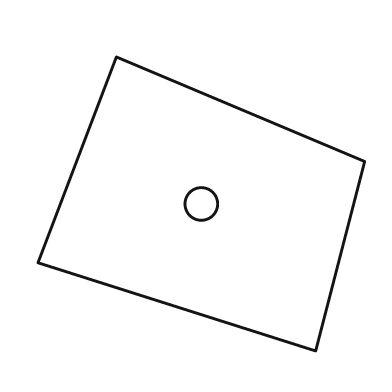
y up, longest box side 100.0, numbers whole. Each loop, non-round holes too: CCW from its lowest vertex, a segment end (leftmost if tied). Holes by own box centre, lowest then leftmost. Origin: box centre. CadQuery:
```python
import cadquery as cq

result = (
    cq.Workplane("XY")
    .moveTo(35.0, -45.0)
    .lineTo(50.0, 13.0)
    .lineTo(-26.0, 45.0)
    .lineTo(-50.0, -18.0)
    .close()
    .moveTo(0.0, 0.0)
    .circle(5.0)
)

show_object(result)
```